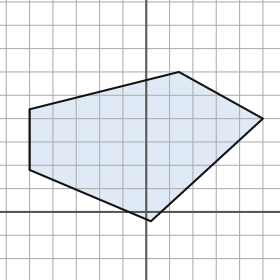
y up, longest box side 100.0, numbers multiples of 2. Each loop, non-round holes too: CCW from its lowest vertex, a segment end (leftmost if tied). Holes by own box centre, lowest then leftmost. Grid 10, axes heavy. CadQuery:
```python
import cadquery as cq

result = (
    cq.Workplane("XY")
    .moveTo(2.0, -4.0)
    .lineTo(50.0, 40.0)
    .lineTo(14.0, 60.0)
    .lineTo(-50.0, 44.0)
    .lineTo(-50.0, 18.0)
    .close()
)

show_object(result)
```